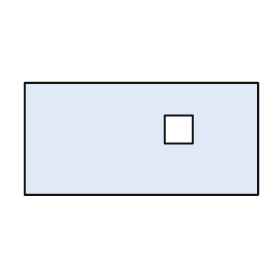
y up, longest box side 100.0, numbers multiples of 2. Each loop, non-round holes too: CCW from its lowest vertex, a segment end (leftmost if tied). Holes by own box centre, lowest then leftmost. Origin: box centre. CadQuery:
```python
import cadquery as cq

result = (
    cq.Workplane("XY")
    .moveTo(-50.0, -24.0)
    .lineTo(50.0, -24.0)
    .lineTo(50.0, 24.0)
    .lineTo(-50.0, 24.0)
    .close()
    .moveTo(10.0, -2.0)
    .lineTo(22.0, -2.0)
    .lineTo(22.0, 10.0)
    .lineTo(10.0, 10.0)
    .close()
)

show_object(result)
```